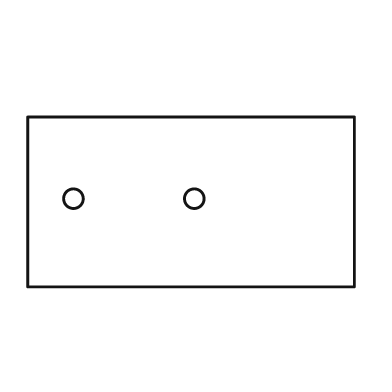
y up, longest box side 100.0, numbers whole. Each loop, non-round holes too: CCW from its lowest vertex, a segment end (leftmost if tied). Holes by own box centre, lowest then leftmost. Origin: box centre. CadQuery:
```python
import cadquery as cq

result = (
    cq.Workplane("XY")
    .moveTo(-50.0, -26.0)
    .lineTo(50.0, -26.0)
    .lineTo(50.0, 26.0)
    .lineTo(-50.0, 26.0)
    .close()
    .moveTo(-36.0, 1.0)
    .circle(3.0)
    .moveTo(1.0, 1.0)
    .circle(3.0)
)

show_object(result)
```